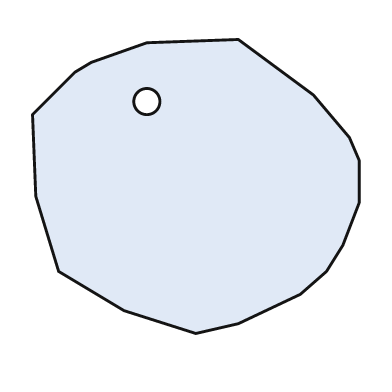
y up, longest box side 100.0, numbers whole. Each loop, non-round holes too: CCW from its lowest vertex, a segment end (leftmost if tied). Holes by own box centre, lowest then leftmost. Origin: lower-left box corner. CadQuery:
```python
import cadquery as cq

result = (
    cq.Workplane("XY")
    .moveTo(50.0, 0.0)
    .lineTo(63.0, 3.0)
    .lineTo(82.0, 12.0)
    .lineTo(90.0, 19.0)
    .lineTo(95.0, 27.0)
    .lineTo(100.0, 40.0)
    .lineTo(100.0, 53.0)
    .lineTo(97.0, 60.0)
    .lineTo(86.0, 73.0)
    .lineTo(63.0, 90.0)
    .lineTo(35.0, 89.0)
    .lineTo(18.0, 83.0)
    .lineTo(13.0, 80.0)
    .lineTo(0.0, 67.0)
    .lineTo(1.0, 42.0)
    .lineTo(8.0, 19.0)
    .lineTo(28.0, 7.0)
    .close()
    .moveTo(35.0, 71.0)
    .circle(4.0)
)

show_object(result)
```